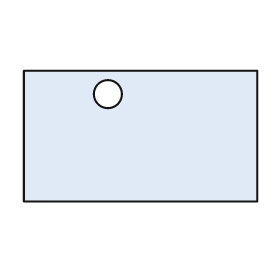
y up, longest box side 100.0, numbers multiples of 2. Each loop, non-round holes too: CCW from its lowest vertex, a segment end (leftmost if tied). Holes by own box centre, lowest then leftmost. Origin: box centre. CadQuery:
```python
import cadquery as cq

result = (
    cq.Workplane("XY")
    .moveTo(-50.0, -28.0)
    .lineTo(50.0, -28.0)
    .lineTo(50.0, 28.0)
    .lineTo(-50.0, 28.0)
    .close()
    .moveTo(-14.0, 18.0)
    .circle(6.0)
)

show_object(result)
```